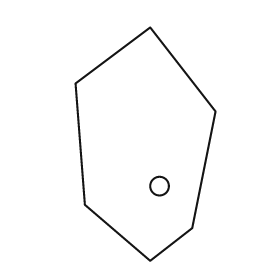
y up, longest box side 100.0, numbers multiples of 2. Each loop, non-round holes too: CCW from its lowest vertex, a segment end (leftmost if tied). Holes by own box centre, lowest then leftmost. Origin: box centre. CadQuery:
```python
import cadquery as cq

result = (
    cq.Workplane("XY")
    .moveTo(2.0, -50.0)
    .lineTo(20.0, -36.0)
    .lineTo(30.0, 14.0)
    .lineTo(2.0, 50.0)
    .lineTo(-30.0, 26.0)
    .lineTo(-26.0, -26.0)
    .close()
    .moveTo(6.0, -18.0)
    .circle(4.0)
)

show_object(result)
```